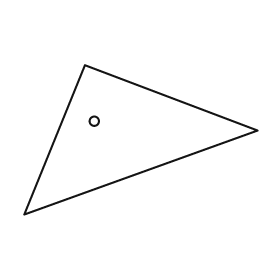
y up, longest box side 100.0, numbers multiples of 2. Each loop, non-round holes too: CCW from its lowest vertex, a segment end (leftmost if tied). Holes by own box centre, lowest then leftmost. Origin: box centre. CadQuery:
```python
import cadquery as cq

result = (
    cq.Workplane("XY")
    .moveTo(-50.0, -32.0)
    .lineTo(50.0, 4.0)
    .lineTo(-24.0, 32.0)
    .close()
    .moveTo(-20.0, 8.0)
    .circle(2.0)
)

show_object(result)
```